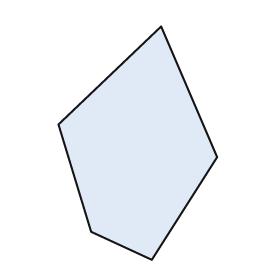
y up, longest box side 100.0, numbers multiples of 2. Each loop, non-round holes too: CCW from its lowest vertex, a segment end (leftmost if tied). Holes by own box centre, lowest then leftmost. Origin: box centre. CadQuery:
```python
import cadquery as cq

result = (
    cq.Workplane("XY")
    .moveTo(6.0, -50.0)
    .lineTo(34.0, -6.0)
    .lineTo(10.0, 50.0)
    .lineTo(-34.0, 8.0)
    .lineTo(-20.0, -38.0)
    .close()
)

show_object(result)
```